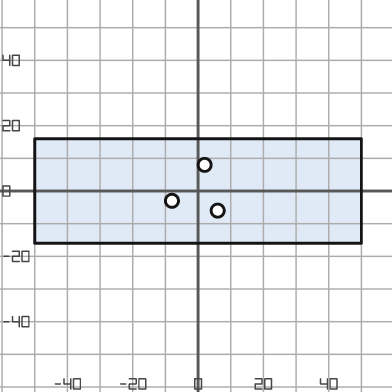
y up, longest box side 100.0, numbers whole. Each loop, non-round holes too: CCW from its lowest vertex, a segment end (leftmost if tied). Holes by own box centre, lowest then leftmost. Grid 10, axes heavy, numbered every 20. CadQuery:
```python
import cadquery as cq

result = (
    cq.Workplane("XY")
    .moveTo(-50.0, -16.0)
    .lineTo(50.0, -16.0)
    .lineTo(50.0, 16.0)
    .lineTo(-50.0, 16.0)
    .close()
    .moveTo(6.0, -6.0)
    .circle(2.0)
    .moveTo(-8.0, -3.0)
    .circle(2.0)
    .moveTo(2.0, 8.0)
    .circle(2.0)
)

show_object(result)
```